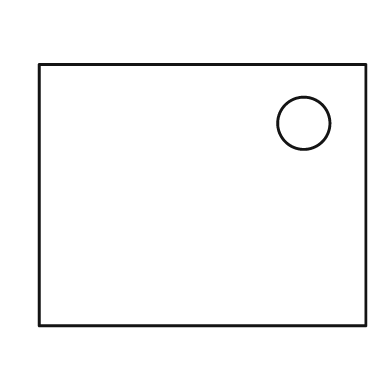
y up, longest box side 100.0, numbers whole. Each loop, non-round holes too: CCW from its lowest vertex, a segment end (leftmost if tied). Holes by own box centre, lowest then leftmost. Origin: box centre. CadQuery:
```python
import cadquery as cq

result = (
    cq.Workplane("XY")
    .moveTo(-50.0, -40.0)
    .lineTo(50.0, -40.0)
    .lineTo(50.0, 40.0)
    .lineTo(-50.0, 40.0)
    .close()
    .moveTo(31.0, 22.0)
    .circle(8.0)
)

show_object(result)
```